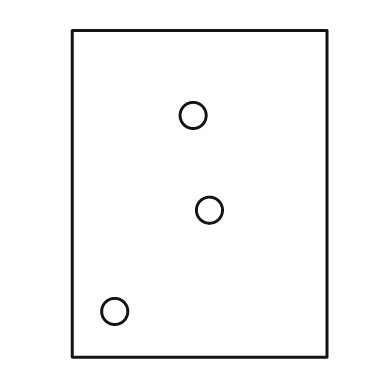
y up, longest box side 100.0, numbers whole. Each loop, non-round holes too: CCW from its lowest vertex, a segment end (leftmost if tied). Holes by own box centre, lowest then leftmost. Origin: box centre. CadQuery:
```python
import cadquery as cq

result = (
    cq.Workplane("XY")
    .moveTo(-39.0, -50.0)
    .lineTo(39.0, -50.0)
    .lineTo(39.0, 50.0)
    .lineTo(-39.0, 50.0)
    .close()
    .moveTo(-26.0, -36.0)
    .circle(4.0)
    .moveTo(3.0, -5.0)
    .circle(4.0)
    .moveTo(-2.0, 24.0)
    .circle(4.0)
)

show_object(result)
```